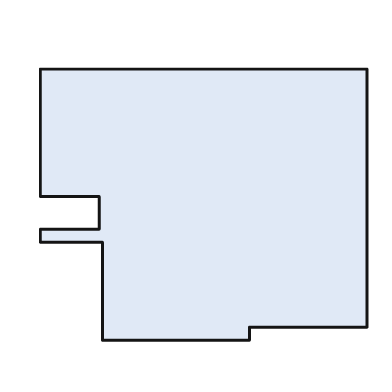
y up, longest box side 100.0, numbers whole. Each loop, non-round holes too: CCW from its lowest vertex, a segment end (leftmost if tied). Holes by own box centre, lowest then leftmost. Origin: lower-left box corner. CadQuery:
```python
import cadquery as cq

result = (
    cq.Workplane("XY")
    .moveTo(19.0, 0.0)
    .lineTo(64.0, 0.0)
    .lineTo(64.0, 4.0)
    .lineTo(100.0, 4.0)
    .lineTo(100.0, 83.0)
    .lineTo(0.0, 83.0)
    .lineTo(0.0, 44.0)
    .lineTo(18.0, 44.0)
    .lineTo(18.0, 34.0)
    .lineTo(0.0, 34.0)
    .lineTo(0.0, 30.0)
    .lineTo(19.0, 30.0)
    .close()
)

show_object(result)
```